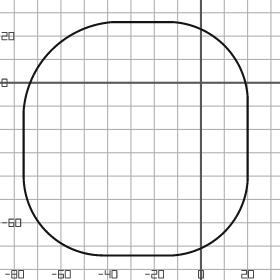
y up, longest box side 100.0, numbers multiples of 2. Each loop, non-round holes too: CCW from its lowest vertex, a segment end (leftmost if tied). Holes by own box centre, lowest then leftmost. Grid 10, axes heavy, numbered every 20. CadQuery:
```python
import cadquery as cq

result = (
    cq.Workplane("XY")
    .moveTo(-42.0, -74.0)
    .lineTo(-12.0, -74.0)
    .threePointArc((10.0, -64.0), (20.0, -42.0))
    .lineTo(20.0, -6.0)
    .threePointArc((10.0, 16.0), (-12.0, 26.0))
    .lineTo(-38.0, 26.0)
    .threePointArc((-64.0, 14.0), (-76.0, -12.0))
    .lineTo(-76.0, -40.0)
    .threePointArc((-66.0, -64.0), (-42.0, -74.0))
    .close()
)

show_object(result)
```